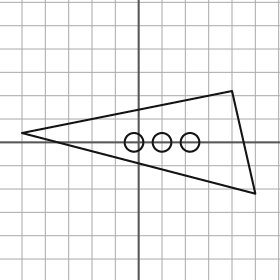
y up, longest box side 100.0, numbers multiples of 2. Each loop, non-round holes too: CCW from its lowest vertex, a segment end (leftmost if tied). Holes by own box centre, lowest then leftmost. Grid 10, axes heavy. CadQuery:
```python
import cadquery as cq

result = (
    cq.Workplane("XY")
    .moveTo(50.0, -22.0)
    .lineTo(40.0, 22.0)
    .lineTo(-50.0, 4.0)
    .close()
    .moveTo(-2.0, 0.0)
    .circle(4.0)
    .moveTo(10.0, 0.0)
    .circle(4.0)
    .moveTo(22.0, 0.0)
    .circle(4.0)
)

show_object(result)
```